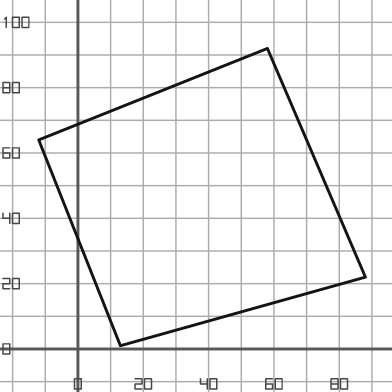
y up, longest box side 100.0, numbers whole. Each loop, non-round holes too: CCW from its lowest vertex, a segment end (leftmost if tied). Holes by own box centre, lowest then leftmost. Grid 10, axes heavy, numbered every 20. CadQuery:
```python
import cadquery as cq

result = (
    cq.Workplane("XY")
    .moveTo(13.0, 1.0)
    .lineTo(88.0, 22.0)
    .lineTo(58.0, 92.0)
    .lineTo(-12.0, 64.0)
    .close()
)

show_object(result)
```